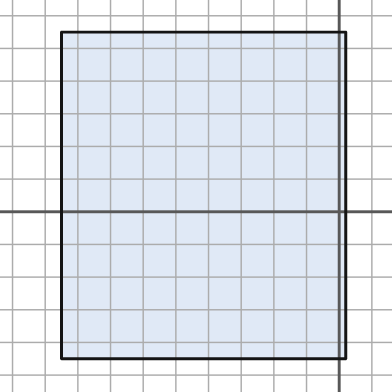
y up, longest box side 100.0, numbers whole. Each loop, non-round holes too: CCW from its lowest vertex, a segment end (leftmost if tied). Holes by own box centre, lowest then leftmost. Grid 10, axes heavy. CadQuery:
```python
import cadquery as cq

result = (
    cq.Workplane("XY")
    .moveTo(-85.0, -45.0)
    .lineTo(2.0, -45.0)
    .lineTo(2.0, 55.0)
    .lineTo(-85.0, 55.0)
    .close()
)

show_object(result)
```